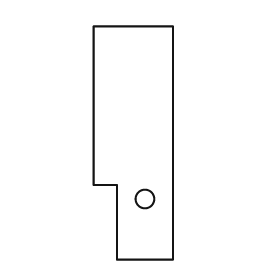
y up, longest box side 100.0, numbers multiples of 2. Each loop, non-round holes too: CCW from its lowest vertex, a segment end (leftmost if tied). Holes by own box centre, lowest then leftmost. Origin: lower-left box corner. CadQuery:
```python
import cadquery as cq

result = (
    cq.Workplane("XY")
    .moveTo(10.0, 0.0)
    .lineTo(34.0, 0.0)
    .lineTo(34.0, 100.0)
    .lineTo(0.0, 100.0)
    .lineTo(0.0, 32.0)
    .lineTo(10.0, 32.0)
    .close()
    .moveTo(22.0, 26.0)
    .circle(4.0)
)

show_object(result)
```